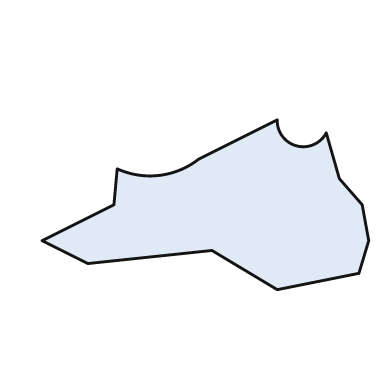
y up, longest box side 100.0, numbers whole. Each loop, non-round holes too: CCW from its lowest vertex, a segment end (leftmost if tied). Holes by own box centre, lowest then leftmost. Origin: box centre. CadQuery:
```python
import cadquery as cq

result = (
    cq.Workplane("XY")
    .moveTo(22.0, -26.0)
    .lineTo(47.0, -21.0)
    .lineTo(50.0, -11.0)
    .lineTo(48.0, 0.0)
    .lineTo(41.0, 8.0)
    .lineTo(37.0, 22.0)
    .threePointArc((28.0, 18.0), (22.0, 26.0))
    .lineTo(-2.0, 14.0)
    .threePointArc((-14.0, 9.0), (-27.0, 11.0))
    .lineTo(-28.0, 0.0)
    .lineTo(-50.0, -11.0)
    .lineTo(-36.0, -18.0)
    .lineTo(2.0, -14.0)
    .close()
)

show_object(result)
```